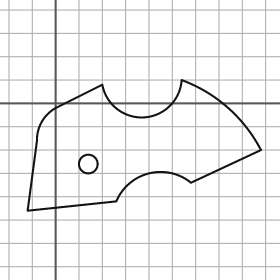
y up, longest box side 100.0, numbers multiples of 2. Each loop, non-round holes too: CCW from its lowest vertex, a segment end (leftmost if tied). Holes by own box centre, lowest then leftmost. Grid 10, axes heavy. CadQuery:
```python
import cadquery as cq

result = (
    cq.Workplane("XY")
    .moveTo(-12.0, -46.0)
    .lineTo(26.0, -42.0)
    .threePointArc((40.0, -30.0), (58.0, -34.0))
    .lineTo(88.0, -20.0)
    .threePointArc((74.0, -2.0), (54.0, 10.0))
    .threePointArc((38.0, -6.0), (20.0, 8.0))
    .lineTo(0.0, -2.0)
    .threePointArc((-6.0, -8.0), (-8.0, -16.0))
    .close()
    .moveTo(14.0, -26.0)
    .circle(4.0)
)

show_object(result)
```